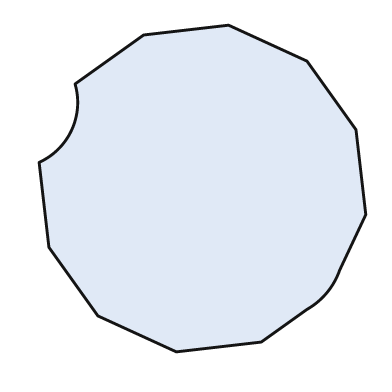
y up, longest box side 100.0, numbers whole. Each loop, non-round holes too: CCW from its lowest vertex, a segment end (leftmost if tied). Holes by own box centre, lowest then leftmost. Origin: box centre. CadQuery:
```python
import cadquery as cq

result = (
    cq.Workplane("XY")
    .moveTo(-8.0, -50.0)
    .lineTo(18.0, -47.0)
    .lineTo(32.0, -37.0)
    .threePointArc((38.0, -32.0), (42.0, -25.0))
    .lineTo(50.0, -8.0)
    .lineTo(47.0, 18.0)
    .lineTo(32.0, 39.0)
    .lineTo(8.0, 50.0)
    .lineTo(-18.0, 47.0)
    .lineTo(-39.0, 32.0)
    .threePointArc((-40.0, 18.0), (-50.0, 8.0))
    .lineTo(-47.0, -18.0)
    .lineTo(-32.0, -39.0)
    .close()
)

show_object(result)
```